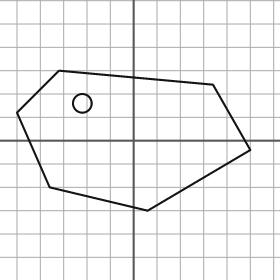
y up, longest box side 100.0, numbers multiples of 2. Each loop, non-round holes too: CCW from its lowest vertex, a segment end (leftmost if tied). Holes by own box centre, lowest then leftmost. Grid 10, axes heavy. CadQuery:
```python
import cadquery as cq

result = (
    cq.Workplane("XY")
    .moveTo(6.0, -30.0)
    .lineTo(50.0, -4.0)
    .lineTo(34.0, 24.0)
    .lineTo(-32.0, 30.0)
    .lineTo(-50.0, 12.0)
    .lineTo(-36.0, -20.0)
    .close()
    .moveTo(-22.0, 16.0)
    .circle(4.0)
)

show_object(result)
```